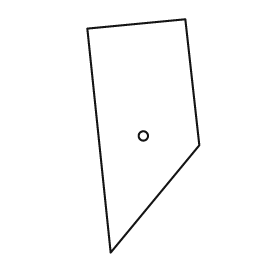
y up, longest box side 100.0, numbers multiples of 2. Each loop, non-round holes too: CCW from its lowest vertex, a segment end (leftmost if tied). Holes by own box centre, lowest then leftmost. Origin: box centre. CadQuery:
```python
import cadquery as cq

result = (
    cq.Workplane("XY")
    .moveTo(-14.0, -50.0)
    .lineTo(24.0, -4.0)
    .lineTo(18.0, 50.0)
    .lineTo(-24.0, 46.0)
    .close()
    .moveTo(0.0, 0.0)
    .circle(2.0)
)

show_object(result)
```